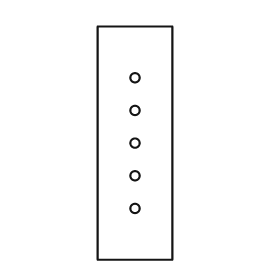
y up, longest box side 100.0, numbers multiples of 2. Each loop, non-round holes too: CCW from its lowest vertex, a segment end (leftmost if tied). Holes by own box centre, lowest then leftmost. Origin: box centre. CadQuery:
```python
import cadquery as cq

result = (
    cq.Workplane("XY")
    .moveTo(-16.0, -50.0)
    .lineTo(16.0, -50.0)
    .lineTo(16.0, 50.0)
    .lineTo(-16.0, 50.0)
    .close()
    .moveTo(0.0, -28.0)
    .circle(2.0)
    .moveTo(0.0, -14.0)
    .circle(2.0)
    .moveTo(0.0, 0.0)
    .circle(2.0)
    .moveTo(0.0, 14.0)
    .circle(2.0)
    .moveTo(0.0, 28.0)
    .circle(2.0)
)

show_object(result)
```